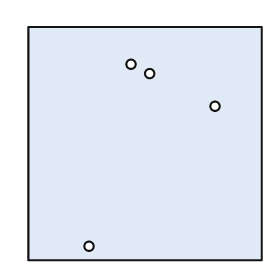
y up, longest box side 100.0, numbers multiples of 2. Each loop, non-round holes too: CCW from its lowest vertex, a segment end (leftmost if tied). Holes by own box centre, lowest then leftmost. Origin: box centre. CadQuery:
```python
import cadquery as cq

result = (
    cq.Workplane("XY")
    .moveTo(-50.0, -50.0)
    .lineTo(50.0, -50.0)
    .lineTo(50.0, 50.0)
    .lineTo(-50.0, 50.0)
    .close()
    .moveTo(-24.0, -44.0)
    .circle(2.0)
    .moveTo(30.0, 16.0)
    .circle(2.0)
    .moveTo(2.0, 30.0)
    .circle(2.0)
    .moveTo(-6.0, 34.0)
    .circle(2.0)
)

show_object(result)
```